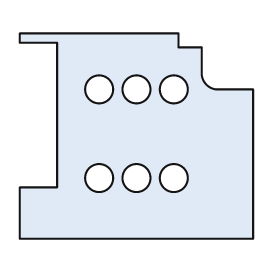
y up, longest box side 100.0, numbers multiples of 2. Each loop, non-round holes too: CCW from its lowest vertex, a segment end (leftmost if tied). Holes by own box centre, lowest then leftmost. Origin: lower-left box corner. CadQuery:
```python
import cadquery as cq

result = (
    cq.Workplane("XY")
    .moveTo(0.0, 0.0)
    .lineTo(100.0, 0.0)
    .lineTo(100.0, 64.0)
    .lineTo(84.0, 64.0)
    .threePointArc((80.0, 66.0), (78.0, 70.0))
    .lineTo(78.0, 82.0)
    .lineTo(68.0, 82.0)
    .lineTo(68.0, 88.0)
    .lineTo(0.0, 88.0)
    .lineTo(0.0, 84.0)
    .lineTo(16.0, 84.0)
    .lineTo(16.0, 22.0)
    .lineTo(0.0, 22.0)
    .close()
    .moveTo(34.0, 26.0)
    .circle(6.0)
    .moveTo(50.0, 26.0)
    .circle(6.0)
    .moveTo(66.0, 26.0)
    .circle(6.0)
    .moveTo(34.0, 64.0)
    .circle(6.0)
    .moveTo(50.0, 64.0)
    .circle(6.0)
    .moveTo(66.0, 64.0)
    .circle(6.0)
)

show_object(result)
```